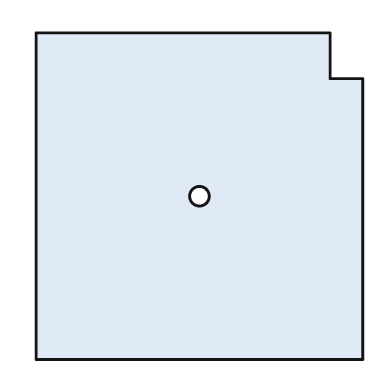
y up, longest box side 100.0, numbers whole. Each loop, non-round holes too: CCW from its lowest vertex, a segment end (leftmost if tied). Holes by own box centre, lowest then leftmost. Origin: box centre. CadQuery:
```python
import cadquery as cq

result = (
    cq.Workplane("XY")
    .moveTo(-50.0, -50.0)
    .lineTo(50.0, -50.0)
    .lineTo(50.0, 36.0)
    .lineTo(40.0, 36.0)
    .lineTo(40.0, 50.0)
    .lineTo(-50.0, 50.0)
    .close()
    .moveTo(0.0, 0.0)
    .circle(3.0)
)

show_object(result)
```